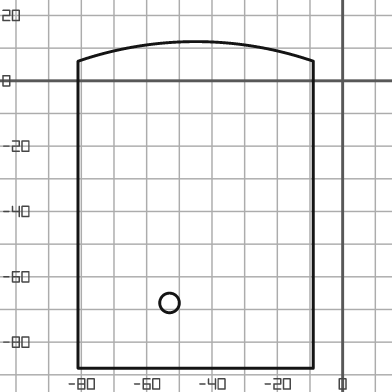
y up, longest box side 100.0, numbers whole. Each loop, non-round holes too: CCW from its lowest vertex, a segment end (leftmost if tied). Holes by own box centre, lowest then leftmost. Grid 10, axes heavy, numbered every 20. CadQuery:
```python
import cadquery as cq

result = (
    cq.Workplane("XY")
    .moveTo(-81.0, -88.0)
    .lineTo(-9.0, -88.0)
    .lineTo(-9.0, 6.0)
    .threePointArc((-45.0, 12.0), (-81.0, 6.0))
    .close()
    .moveTo(-53.0, -68.0)
    .circle(3.0)
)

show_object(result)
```